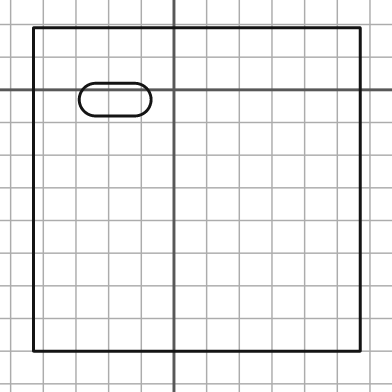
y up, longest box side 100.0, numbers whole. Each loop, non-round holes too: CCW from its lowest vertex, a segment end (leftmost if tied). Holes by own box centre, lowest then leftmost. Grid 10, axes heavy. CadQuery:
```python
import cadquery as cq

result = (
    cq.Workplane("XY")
    .moveTo(-43.0, -80.0)
    .lineTo(57.0, -80.0)
    .lineTo(57.0, 19.0)
    .lineTo(-43.0, 19.0)
    .close()
    .moveTo(-24.0, -8.0)
    .lineTo(-12.0, -8.0)
    .threePointArc((-7.0, -3.0), (-12.0, 2.0))
    .lineTo(-24.0, 2.0)
    .threePointArc((-29.0, -3.0), (-24.0, -8.0))
    .close()
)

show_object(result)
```